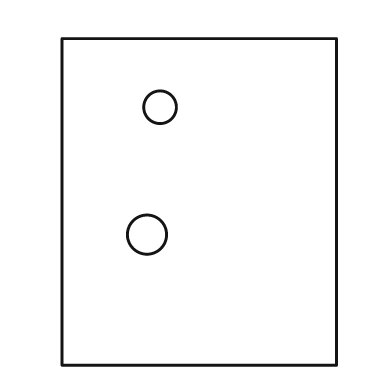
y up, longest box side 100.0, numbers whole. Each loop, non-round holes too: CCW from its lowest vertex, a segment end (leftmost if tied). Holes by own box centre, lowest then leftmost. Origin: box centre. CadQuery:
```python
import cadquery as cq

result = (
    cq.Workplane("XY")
    .moveTo(-42.0, -50.0)
    .lineTo(42.0, -50.0)
    .lineTo(42.0, 50.0)
    .lineTo(-42.0, 50.0)
    .close()
    .moveTo(-16.0, -10.0)
    .circle(6.0)
    .moveTo(-12.0, 29.0)
    .circle(5.0)
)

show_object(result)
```